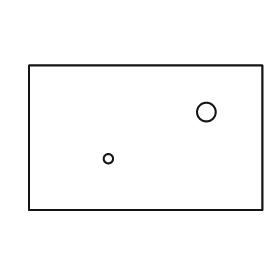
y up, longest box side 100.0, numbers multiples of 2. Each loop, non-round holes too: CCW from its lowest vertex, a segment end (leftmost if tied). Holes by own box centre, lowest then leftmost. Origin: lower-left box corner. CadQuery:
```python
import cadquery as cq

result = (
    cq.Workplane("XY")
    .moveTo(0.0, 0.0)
    .lineTo(100.0, 0.0)
    .lineTo(100.0, 62.0)
    .lineTo(0.0, 62.0)
    .close()
    .moveTo(34.0, 22.0)
    .circle(2.0)
    .moveTo(76.0, 42.0)
    .circle(4.0)
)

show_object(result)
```